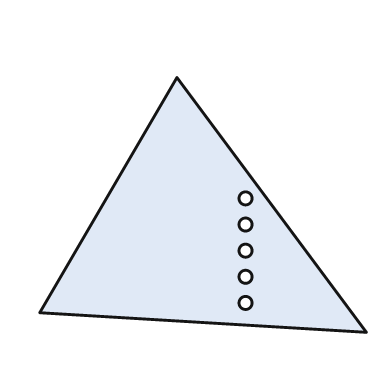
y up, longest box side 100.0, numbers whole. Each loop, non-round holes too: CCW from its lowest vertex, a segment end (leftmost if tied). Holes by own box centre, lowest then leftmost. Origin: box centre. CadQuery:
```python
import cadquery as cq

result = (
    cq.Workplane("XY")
    .moveTo(50.0, -39.0)
    .lineTo(-8.0, 39.0)
    .lineTo(-50.0, -33.0)
    .close()
    .moveTo(13.0, -30.0)
    .circle(2.0)
    .moveTo(13.0, -22.0)
    .circle(2.0)
    .moveTo(13.0, -14.0)
    .circle(2.0)
    .moveTo(13.0, -6.0)
    .circle(2.0)
    .moveTo(13.0, 2.0)
    .circle(2.0)
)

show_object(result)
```